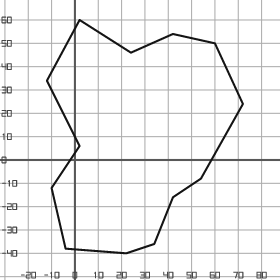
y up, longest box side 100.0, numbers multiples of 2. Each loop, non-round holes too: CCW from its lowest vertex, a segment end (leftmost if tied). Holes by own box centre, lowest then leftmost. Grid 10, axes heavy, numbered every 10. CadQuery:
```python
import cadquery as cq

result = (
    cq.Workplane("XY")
    .moveTo(22.0, -40.0)
    .lineTo(34.0, -36.0)
    .lineTo(42.0, -16.0)
    .lineTo(54.0, -8.0)
    .lineTo(72.0, 24.0)
    .lineTo(60.0, 50.0)
    .lineTo(42.0, 54.0)
    .lineTo(24.0, 46.0)
    .lineTo(2.0, 60.0)
    .lineTo(-12.0, 34.0)
    .lineTo(2.0, 6.0)
    .lineTo(-10.0, -12.0)
    .lineTo(-4.0, -38.0)
    .close()
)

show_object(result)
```